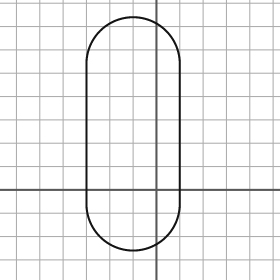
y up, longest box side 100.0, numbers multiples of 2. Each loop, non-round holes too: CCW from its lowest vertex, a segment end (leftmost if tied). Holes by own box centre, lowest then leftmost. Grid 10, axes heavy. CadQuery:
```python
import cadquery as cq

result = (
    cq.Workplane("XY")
    .moveTo(-30.0, -6.0)
    .threePointArc((-10.0, -26.0), (10.0, -6.0))
    .lineTo(10.0, 54.0)
    .threePointArc((-10.0, 74.0), (-30.0, 54.0))
    .close()
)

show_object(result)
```